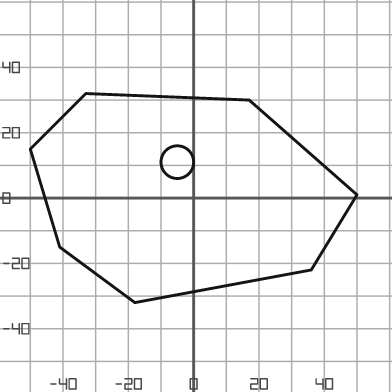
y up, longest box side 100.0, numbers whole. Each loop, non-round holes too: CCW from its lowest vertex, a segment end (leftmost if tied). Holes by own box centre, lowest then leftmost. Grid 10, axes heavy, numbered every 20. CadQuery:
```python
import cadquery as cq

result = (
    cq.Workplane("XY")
    .moveTo(-18.0, -32.0)
    .lineTo(36.0, -22.0)
    .lineTo(50.0, 1.0)
    .lineTo(17.0, 30.0)
    .lineTo(-33.0, 32.0)
    .lineTo(-50.0, 15.0)
    .lineTo(-41.0, -15.0)
    .close()
    .moveTo(-5.0, 11.0)
    .circle(5.0)
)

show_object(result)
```